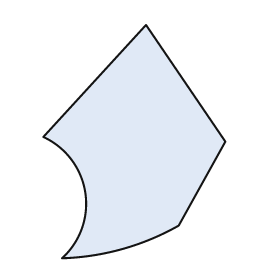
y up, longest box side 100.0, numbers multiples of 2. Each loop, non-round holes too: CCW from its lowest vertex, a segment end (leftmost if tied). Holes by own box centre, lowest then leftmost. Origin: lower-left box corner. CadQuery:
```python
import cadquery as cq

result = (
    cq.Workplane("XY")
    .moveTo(8.0, 0.0)
    .threePointArc((34.0, 4.0), (58.0, 14.0))
    .lineTo(78.0, 50.0)
    .lineTo(44.0, 100.0)
    .lineTo(0.0, 52.0)
    .threePointArc((18.0, 28.0), (8.0, 0.0))
    .close()
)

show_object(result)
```